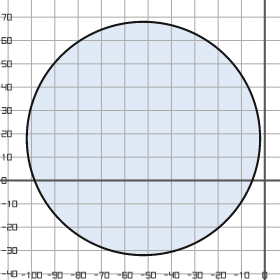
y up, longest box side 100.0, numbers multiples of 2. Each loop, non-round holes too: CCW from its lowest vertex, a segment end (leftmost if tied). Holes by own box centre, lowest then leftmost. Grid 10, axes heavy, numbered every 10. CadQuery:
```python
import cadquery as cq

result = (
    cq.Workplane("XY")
    .moveTo(-52.0, 18.0)
    .circle(50.0)
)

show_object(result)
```